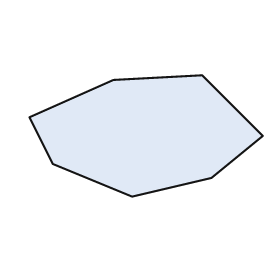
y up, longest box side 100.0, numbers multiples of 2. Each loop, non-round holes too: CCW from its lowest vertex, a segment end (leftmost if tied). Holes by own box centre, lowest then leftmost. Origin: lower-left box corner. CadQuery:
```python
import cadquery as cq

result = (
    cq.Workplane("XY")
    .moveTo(44.0, 0.0)
    .lineTo(78.0, 8.0)
    .lineTo(100.0, 26.0)
    .lineTo(74.0, 52.0)
    .lineTo(36.0, 50.0)
    .lineTo(0.0, 34.0)
    .lineTo(10.0, 14.0)
    .close()
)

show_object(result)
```